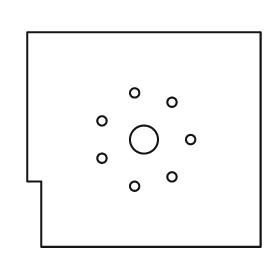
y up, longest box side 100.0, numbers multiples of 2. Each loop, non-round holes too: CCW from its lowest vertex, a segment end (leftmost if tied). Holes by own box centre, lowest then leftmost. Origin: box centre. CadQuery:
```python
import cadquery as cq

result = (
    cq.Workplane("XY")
    .moveTo(-44.0, -46.0)
    .lineTo(50.0, -46.0)
    .lineTo(50.0, 46.0)
    .lineTo(-50.0, 46.0)
    .lineTo(-50.0, -18.0)
    .lineTo(-44.0, -18.0)
    .close()
    .moveTo(-4.0, -20.0)
    .circle(2.0)
    .moveTo(12.0, -16.0)
    .circle(2.0)
    .moveTo(-18.0, -8.0)
    .circle(2.0)
    .moveTo(0.0, 0.0)
    .circle(6.0)
    .moveTo(20.0, 0.0)
    .circle(2.0)
    .moveTo(-18.0, 8.0)
    .circle(2.0)
    .moveTo(12.0, 16.0)
    .circle(2.0)
    .moveTo(-4.0, 20.0)
    .circle(2.0)
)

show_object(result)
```